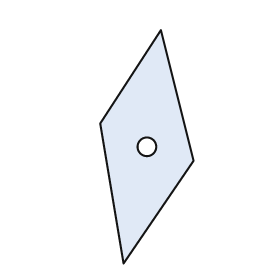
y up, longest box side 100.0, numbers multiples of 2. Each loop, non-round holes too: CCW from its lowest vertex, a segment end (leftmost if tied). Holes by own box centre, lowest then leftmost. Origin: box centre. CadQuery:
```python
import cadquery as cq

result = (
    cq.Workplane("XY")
    .moveTo(-10.0, -50.0)
    .lineTo(20.0, -6.0)
    .lineTo(6.0, 50.0)
    .lineTo(-20.0, 10.0)
    .close()
    .moveTo(0.0, 0.0)
    .circle(4.0)
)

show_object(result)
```